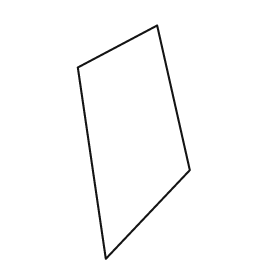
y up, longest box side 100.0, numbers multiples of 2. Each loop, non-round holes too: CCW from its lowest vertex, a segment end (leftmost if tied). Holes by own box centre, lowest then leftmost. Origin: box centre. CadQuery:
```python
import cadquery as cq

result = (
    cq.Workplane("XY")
    .moveTo(-12.0, -50.0)
    .lineTo(24.0, -12.0)
    .lineTo(10.0, 50.0)
    .lineTo(-24.0, 32.0)
    .close()
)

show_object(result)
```